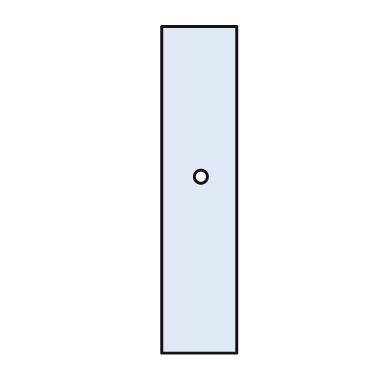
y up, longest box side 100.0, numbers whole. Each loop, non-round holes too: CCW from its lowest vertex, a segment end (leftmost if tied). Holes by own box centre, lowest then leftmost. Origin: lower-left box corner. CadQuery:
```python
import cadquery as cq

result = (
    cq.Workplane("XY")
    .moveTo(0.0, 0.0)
    .lineTo(23.0, 0.0)
    .lineTo(23.0, 100.0)
    .lineTo(0.0, 100.0)
    .close()
    .moveTo(12.0, 54.0)
    .circle(2.0)
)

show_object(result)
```